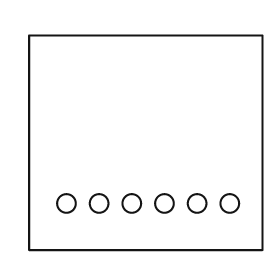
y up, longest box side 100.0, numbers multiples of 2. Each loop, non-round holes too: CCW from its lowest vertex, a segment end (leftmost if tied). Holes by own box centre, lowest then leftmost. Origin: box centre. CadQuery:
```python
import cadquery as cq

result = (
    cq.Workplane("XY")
    .moveTo(-50.0, -46.0)
    .lineTo(50.0, -46.0)
    .lineTo(50.0, 46.0)
    .lineTo(-50.0, 46.0)
    .close()
    .moveTo(-34.0, -26.0)
    .circle(4.0)
    .moveTo(-20.0, -26.0)
    .circle(4.0)
    .moveTo(-6.0, -26.0)
    .circle(4.0)
    .moveTo(8.0, -26.0)
    .circle(4.0)
    .moveTo(22.0, -26.0)
    .circle(4.0)
    .moveTo(36.0, -26.0)
    .circle(4.0)
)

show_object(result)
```